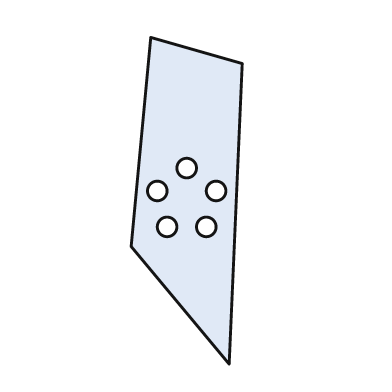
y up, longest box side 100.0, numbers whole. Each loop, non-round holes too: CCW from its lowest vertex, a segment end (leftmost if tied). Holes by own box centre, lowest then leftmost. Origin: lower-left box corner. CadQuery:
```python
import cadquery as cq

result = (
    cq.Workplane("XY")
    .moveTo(30.0, 0.0)
    .lineTo(34.0, 92.0)
    .lineTo(6.0, 100.0)
    .lineTo(0.0, 36.0)
    .close()
    .moveTo(11.0, 42.0)
    .circle(3.0)
    .moveTo(23.0, 42.0)
    .circle(3.0)
    .moveTo(8.0, 53.0)
    .circle(3.0)
    .moveTo(26.0, 53.0)
    .circle(3.0)
    .moveTo(17.0, 60.0)
    .circle(3.0)
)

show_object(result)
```